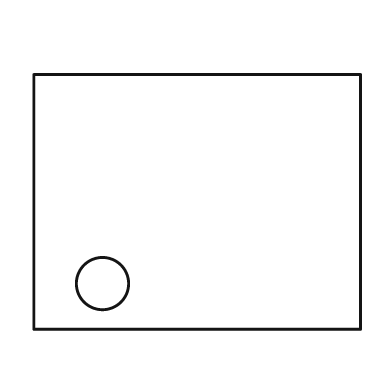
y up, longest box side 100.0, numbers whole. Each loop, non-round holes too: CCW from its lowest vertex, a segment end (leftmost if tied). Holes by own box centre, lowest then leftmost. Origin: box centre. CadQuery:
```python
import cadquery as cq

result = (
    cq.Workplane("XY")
    .moveTo(-50.0, -39.0)
    .lineTo(50.0, -39.0)
    .lineTo(50.0, 39.0)
    .lineTo(-50.0, 39.0)
    .close()
    .moveTo(-29.0, -25.0)
    .circle(8.0)
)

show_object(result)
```